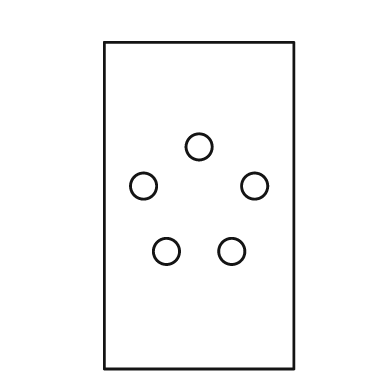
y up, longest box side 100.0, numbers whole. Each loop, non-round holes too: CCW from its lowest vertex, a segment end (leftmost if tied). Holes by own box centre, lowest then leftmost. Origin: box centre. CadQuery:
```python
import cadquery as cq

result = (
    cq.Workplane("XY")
    .moveTo(-29.0, -50.0)
    .lineTo(29.0, -50.0)
    .lineTo(29.0, 50.0)
    .lineTo(-29.0, 50.0)
    .close()
    .moveTo(-10.0, -14.0)
    .circle(4.0)
    .moveTo(10.0, -14.0)
    .circle(4.0)
    .moveTo(-17.0, 6.0)
    .circle(4.0)
    .moveTo(17.0, 6.0)
    .circle(4.0)
    .moveTo(0.0, 18.0)
    .circle(4.0)
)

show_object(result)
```